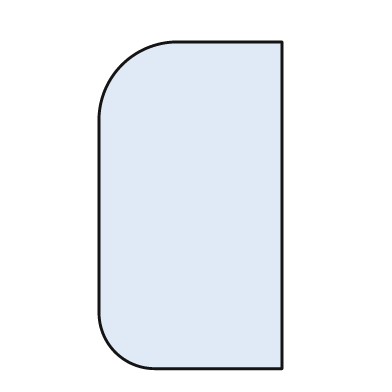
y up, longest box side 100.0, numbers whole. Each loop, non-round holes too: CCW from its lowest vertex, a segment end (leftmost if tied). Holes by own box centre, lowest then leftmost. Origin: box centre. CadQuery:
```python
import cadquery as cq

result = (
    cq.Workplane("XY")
    .moveTo(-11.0, -50.0)
    .lineTo(28.0, -50.0)
    .lineTo(28.0, 50.0)
    .lineTo(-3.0, 50.0)
    .threePointArc((-21.0, 43.0), (-28.0, 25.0))
    .lineTo(-28.0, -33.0)
    .threePointArc((-23.0, -45.0), (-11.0, -50.0))
    .close()
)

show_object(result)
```